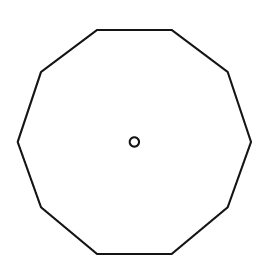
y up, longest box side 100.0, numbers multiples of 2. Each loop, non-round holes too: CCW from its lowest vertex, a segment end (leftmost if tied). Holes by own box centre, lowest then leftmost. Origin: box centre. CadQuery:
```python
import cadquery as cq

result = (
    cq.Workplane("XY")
    .moveTo(-16.0, -48.0)
    .lineTo(16.0, -48.0)
    .lineTo(40.0, -28.0)
    .lineTo(50.0, 0.0)
    .lineTo(40.0, 30.0)
    .lineTo(16.0, 48.0)
    .lineTo(-16.0, 48.0)
    .lineTo(-40.0, 30.0)
    .lineTo(-50.0, 0.0)
    .lineTo(-40.0, -28.0)
    .close()
    .moveTo(0.0, 0.0)
    .circle(2.0)
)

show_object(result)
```